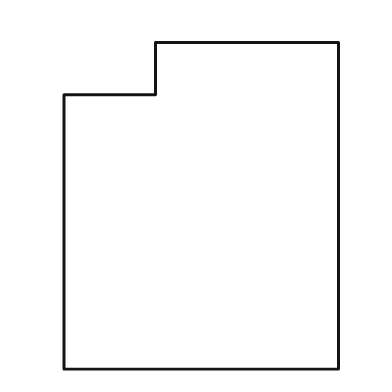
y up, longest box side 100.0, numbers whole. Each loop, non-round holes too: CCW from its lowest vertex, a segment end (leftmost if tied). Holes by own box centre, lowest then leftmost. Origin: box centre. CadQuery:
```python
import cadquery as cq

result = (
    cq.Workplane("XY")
    .moveTo(-42.0, -50.0)
    .lineTo(42.0, -50.0)
    .lineTo(42.0, 50.0)
    .lineTo(-14.0, 50.0)
    .lineTo(-14.0, 34.0)
    .lineTo(-42.0, 34.0)
    .close()
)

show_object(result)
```